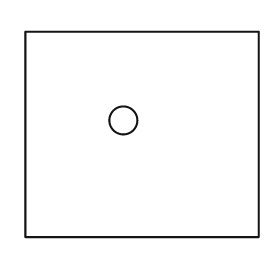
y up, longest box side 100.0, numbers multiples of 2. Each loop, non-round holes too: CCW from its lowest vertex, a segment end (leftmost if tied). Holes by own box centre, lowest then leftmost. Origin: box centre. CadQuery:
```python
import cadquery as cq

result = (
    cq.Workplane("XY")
    .moveTo(-50.0, -44.0)
    .lineTo(50.0, -44.0)
    .lineTo(50.0, 44.0)
    .lineTo(-50.0, 44.0)
    .close()
    .moveTo(-8.0, 6.0)
    .circle(6.0)
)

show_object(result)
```